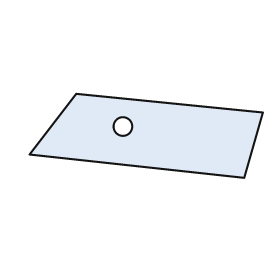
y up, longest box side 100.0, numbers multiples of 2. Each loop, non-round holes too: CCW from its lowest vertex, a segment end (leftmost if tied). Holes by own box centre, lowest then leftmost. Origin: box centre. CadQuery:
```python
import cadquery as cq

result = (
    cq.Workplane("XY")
    .moveTo(42.0, -18.0)
    .lineTo(50.0, 10.0)
    .lineTo(-30.0, 18.0)
    .lineTo(-50.0, -8.0)
    .close()
    .moveTo(-10.0, 4.0)
    .circle(4.0)
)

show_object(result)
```